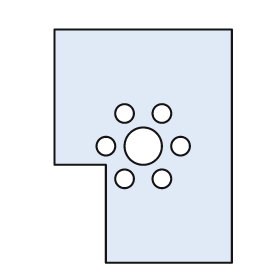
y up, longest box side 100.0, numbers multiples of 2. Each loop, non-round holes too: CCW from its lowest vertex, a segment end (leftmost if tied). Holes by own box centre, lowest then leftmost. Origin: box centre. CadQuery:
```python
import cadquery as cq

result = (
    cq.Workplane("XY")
    .moveTo(-16.0, -50.0)
    .lineTo(38.0, -50.0)
    .lineTo(38.0, 50.0)
    .lineTo(-38.0, 50.0)
    .lineTo(-38.0, -8.0)
    .lineTo(-16.0, -8.0)
    .close()
    .moveTo(-8.0, -14.0)
    .circle(4.0)
    .moveTo(8.0, -14.0)
    .circle(4.0)
    .moveTo(-16.0, 0.0)
    .circle(4.0)
    .moveTo(0.0, 0.0)
    .circle(8.0)
    .moveTo(16.0, 0.0)
    .circle(4.0)
    .moveTo(-8.0, 14.0)
    .circle(4.0)
    .moveTo(8.0, 14.0)
    .circle(4.0)
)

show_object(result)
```